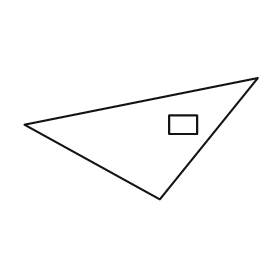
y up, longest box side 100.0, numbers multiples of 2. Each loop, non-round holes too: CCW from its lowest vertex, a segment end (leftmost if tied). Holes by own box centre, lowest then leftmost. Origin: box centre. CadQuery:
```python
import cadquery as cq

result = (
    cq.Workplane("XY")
    .moveTo(8.0, -26.0)
    .lineTo(50.0, 26.0)
    .lineTo(-50.0, 6.0)
    .close()
    .moveTo(12.0, 2.0)
    .lineTo(24.0, 2.0)
    .lineTo(24.0, 10.0)
    .lineTo(12.0, 10.0)
    .close()
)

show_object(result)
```